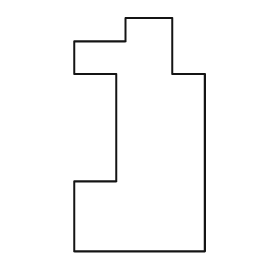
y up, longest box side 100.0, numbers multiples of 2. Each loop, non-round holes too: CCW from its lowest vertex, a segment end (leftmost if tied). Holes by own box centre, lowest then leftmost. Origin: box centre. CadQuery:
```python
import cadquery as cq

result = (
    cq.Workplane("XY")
    .moveTo(-28.0, -50.0)
    .lineTo(28.0, -50.0)
    .lineTo(28.0, 26.0)
    .lineTo(14.0, 26.0)
    .lineTo(14.0, 50.0)
    .lineTo(-6.0, 50.0)
    .lineTo(-6.0, 40.0)
    .lineTo(-28.0, 40.0)
    .lineTo(-28.0, 26.0)
    .lineTo(-10.0, 26.0)
    .lineTo(-10.0, -20.0)
    .lineTo(-28.0, -20.0)
    .close()
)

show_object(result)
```